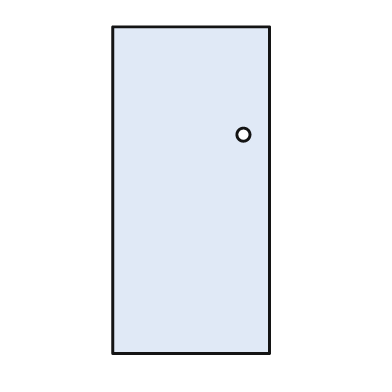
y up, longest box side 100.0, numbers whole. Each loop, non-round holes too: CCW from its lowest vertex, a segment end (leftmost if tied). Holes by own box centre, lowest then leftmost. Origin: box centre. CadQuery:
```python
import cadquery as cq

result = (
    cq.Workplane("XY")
    .moveTo(-24.0, -50.0)
    .lineTo(24.0, -50.0)
    .lineTo(24.0, 50.0)
    .lineTo(-24.0, 50.0)
    .close()
    .moveTo(16.0, 17.0)
    .circle(2.0)
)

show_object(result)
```